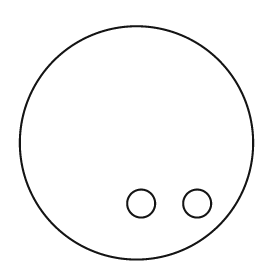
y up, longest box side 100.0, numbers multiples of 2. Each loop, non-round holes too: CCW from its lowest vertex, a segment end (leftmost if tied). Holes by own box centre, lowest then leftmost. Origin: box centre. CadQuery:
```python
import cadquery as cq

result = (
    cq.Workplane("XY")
    .moveTo(0.0, 0.0)
    .circle(50.0)
    .moveTo(2.0, -26.0)
    .circle(6.0)
    .moveTo(26.0, -26.0)
    .circle(6.0)
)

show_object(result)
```